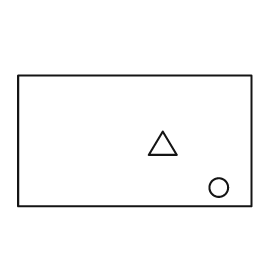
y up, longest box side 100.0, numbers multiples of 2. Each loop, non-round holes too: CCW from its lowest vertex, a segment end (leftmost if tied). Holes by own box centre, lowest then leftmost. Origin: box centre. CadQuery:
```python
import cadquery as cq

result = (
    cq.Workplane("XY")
    .moveTo(-50.0, -28.0)
    .lineTo(50.0, -28.0)
    .lineTo(50.0, 28.0)
    .lineTo(-50.0, 28.0)
    .close()
    .moveTo(36.0, -20.0)
    .circle(4.0)
    .moveTo(6.0, -6.0)
    .lineTo(18.0, -6.0)
    .lineTo(12.0, 4.0)
    .close()
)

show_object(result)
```